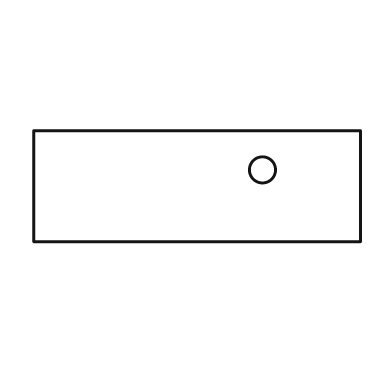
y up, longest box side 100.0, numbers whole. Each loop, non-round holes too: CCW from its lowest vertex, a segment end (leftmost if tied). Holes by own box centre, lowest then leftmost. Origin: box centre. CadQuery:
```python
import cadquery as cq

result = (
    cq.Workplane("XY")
    .moveTo(-50.0, -17.0)
    .lineTo(50.0, -17.0)
    .lineTo(50.0, 17.0)
    .lineTo(-50.0, 17.0)
    .close()
    .moveTo(20.0, 5.0)
    .circle(4.0)
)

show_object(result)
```